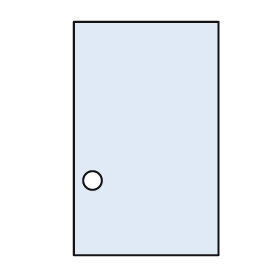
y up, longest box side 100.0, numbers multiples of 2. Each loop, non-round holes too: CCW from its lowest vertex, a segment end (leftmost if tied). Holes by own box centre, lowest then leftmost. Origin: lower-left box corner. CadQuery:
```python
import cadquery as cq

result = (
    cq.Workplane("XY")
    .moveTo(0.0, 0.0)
    .lineTo(62.0, 0.0)
    .lineTo(62.0, 100.0)
    .lineTo(0.0, 100.0)
    .close()
    .moveTo(8.0, 32.0)
    .circle(4.0)
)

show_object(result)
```